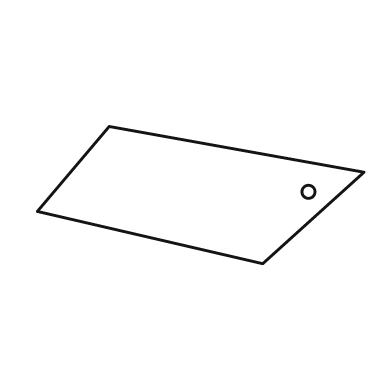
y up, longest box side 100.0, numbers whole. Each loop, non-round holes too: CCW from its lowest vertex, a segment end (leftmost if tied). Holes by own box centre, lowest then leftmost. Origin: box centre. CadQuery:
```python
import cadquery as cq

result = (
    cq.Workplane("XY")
    .moveTo(19.0, -21.0)
    .lineTo(50.0, 7.0)
    .lineTo(-28.0, 21.0)
    .lineTo(-50.0, -5.0)
    .close()
    .moveTo(33.0, 1.0)
    .circle(2.0)
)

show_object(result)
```